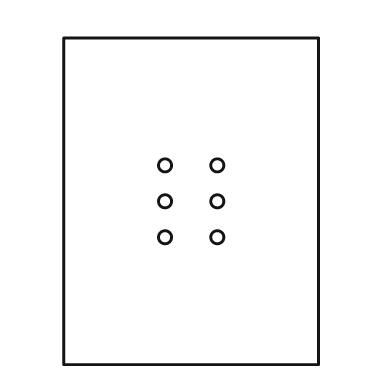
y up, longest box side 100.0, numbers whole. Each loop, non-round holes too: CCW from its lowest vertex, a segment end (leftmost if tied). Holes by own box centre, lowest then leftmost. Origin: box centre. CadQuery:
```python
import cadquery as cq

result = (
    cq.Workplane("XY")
    .moveTo(-39.0, -50.0)
    .lineTo(39.0, -50.0)
    .lineTo(39.0, 50.0)
    .lineTo(-39.0, 50.0)
    .close()
    .moveTo(-8.0, -11.0)
    .circle(2.0)
    .moveTo(8.0, -11.0)
    .circle(2.0)
    .moveTo(-8.0, 0.0)
    .circle(2.0)
    .moveTo(8.0, 0.0)
    .circle(2.0)
    .moveTo(-8.0, 11.0)
    .circle(2.0)
    .moveTo(8.0, 11.0)
    .circle(2.0)
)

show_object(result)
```